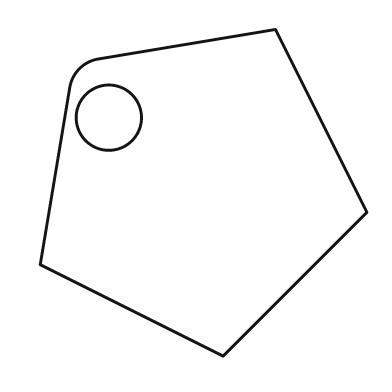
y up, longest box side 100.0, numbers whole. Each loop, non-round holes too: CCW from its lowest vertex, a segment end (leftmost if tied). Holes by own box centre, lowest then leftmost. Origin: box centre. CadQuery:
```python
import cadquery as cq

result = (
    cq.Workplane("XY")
    .moveTo(6.0, -50.0)
    .lineTo(50.0, -6.0)
    .lineTo(22.0, 50.0)
    .lineTo(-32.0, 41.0)
    .threePointArc((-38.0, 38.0), (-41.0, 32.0))
    .lineTo(-50.0, -22.0)
    .close()
    .moveTo(-29.0, 23.0)
    .circle(10.0)
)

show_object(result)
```